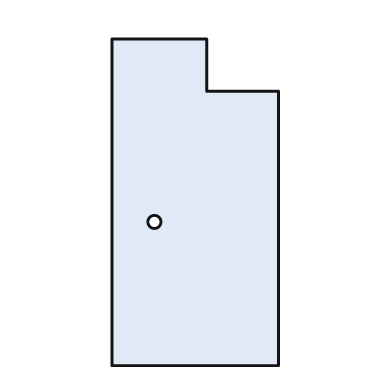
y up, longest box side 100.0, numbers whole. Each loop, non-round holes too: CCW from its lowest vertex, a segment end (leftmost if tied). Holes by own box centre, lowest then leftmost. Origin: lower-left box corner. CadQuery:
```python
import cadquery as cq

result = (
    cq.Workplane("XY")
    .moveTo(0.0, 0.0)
    .lineTo(51.0, 0.0)
    .lineTo(51.0, 84.0)
    .lineTo(29.0, 84.0)
    .lineTo(29.0, 100.0)
    .lineTo(0.0, 100.0)
    .close()
    .moveTo(13.0, 44.0)
    .circle(2.0)
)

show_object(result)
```